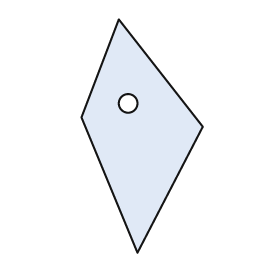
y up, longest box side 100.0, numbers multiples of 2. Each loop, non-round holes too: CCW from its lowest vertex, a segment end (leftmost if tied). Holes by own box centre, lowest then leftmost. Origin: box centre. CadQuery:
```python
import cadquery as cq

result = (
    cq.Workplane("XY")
    .moveTo(-2.0, -50.0)
    .lineTo(26.0, 4.0)
    .lineTo(-10.0, 50.0)
    .lineTo(-26.0, 8.0)
    .close()
    .moveTo(-6.0, 14.0)
    .circle(4.0)
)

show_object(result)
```